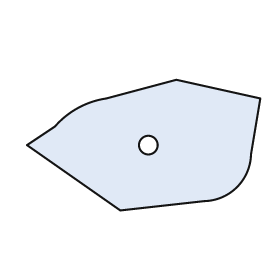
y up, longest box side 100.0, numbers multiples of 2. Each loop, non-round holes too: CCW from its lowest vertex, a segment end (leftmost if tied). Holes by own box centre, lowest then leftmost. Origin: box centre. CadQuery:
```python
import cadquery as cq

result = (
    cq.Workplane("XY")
    .moveTo(-10.0, -28.0)
    .lineTo(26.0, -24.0)
    .threePointArc((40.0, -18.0), (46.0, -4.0))
    .lineTo(50.0, 20.0)
    .lineTo(14.0, 28.0)
    .lineTo(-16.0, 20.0)
    .threePointArc((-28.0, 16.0), (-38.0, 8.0))
    .lineTo(-50.0, 0.0)
    .close()
    .moveTo(2.0, 0.0)
    .circle(4.0)
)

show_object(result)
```